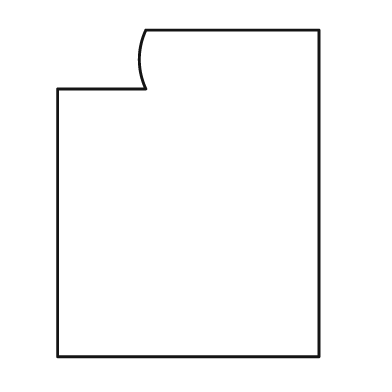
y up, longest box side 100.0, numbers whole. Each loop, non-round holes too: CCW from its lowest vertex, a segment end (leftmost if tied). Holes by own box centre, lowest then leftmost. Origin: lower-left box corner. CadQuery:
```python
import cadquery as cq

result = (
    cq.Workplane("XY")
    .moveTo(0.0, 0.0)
    .lineTo(80.0, 0.0)
    .lineTo(80.0, 100.0)
    .lineTo(27.0, 100.0)
    .threePointArc((25.0, 91.0), (27.0, 82.0))
    .lineTo(0.0, 82.0)
    .close()
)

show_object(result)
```